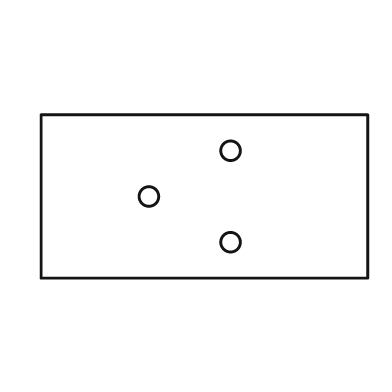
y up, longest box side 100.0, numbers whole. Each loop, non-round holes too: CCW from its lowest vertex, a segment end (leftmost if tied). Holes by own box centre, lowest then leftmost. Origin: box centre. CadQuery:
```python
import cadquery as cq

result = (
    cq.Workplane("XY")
    .moveTo(-50.0, -25.0)
    .lineTo(50.0, -25.0)
    .lineTo(50.0, 25.0)
    .lineTo(-50.0, 25.0)
    .close()
    .moveTo(8.0, -14.0)
    .circle(3.0)
    .moveTo(-17.0, 0.0)
    .circle(3.0)
    .moveTo(8.0, 14.0)
    .circle(3.0)
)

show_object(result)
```